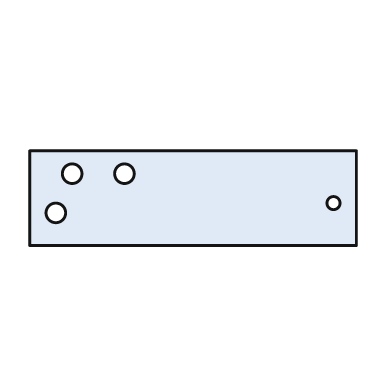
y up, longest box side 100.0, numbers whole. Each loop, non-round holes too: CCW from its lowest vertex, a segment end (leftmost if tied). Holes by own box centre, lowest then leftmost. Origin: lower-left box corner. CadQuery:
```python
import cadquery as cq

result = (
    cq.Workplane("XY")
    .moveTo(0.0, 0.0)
    .lineTo(100.0, 0.0)
    .lineTo(100.0, 29.0)
    .lineTo(0.0, 29.0)
    .close()
    .moveTo(8.0, 10.0)
    .circle(3.0)
    .moveTo(93.0, 13.0)
    .circle(2.0)
    .moveTo(13.0, 22.0)
    .circle(3.0)
    .moveTo(29.0, 22.0)
    .circle(3.0)
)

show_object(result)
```